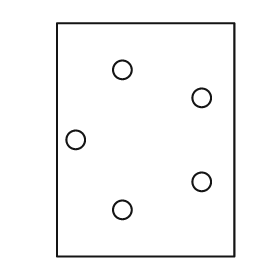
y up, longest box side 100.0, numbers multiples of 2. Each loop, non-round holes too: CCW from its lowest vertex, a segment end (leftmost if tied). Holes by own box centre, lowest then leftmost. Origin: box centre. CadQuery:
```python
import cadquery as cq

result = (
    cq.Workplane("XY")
    .moveTo(-38.0, -50.0)
    .lineTo(38.0, -50.0)
    .lineTo(38.0, 50.0)
    .lineTo(-38.0, 50.0)
    .close()
    .moveTo(-10.0, -30.0)
    .circle(4.0)
    .moveTo(24.0, -18.0)
    .circle(4.0)
    .moveTo(-30.0, 0.0)
    .circle(4.0)
    .moveTo(24.0, 18.0)
    .circle(4.0)
    .moveTo(-10.0, 30.0)
    .circle(4.0)
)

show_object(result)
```